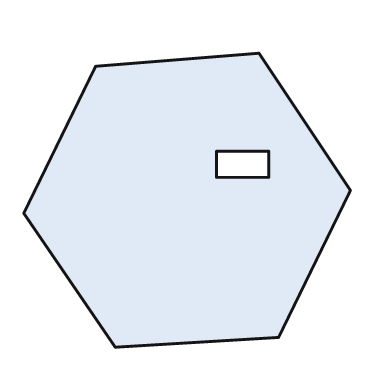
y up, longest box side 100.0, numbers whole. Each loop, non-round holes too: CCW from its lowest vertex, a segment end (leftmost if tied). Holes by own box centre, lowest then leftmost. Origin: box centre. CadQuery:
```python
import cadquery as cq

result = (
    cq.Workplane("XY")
    .moveTo(-22.0, -45.0)
    .lineTo(28.0, -42.0)
    .lineTo(50.0, 3.0)
    .lineTo(22.0, 45.0)
    .lineTo(-28.0, 41.0)
    .lineTo(-50.0, -4.0)
    .close()
    .moveTo(9.0, 7.0)
    .lineTo(25.0, 7.0)
    .lineTo(25.0, 15.0)
    .lineTo(9.0, 15.0)
    .close()
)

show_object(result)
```